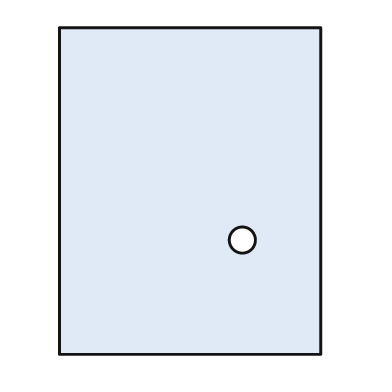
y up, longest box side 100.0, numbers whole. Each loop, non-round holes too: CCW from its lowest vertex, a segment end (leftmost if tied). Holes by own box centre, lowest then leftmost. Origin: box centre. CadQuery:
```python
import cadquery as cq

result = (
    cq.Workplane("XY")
    .moveTo(-40.0, -50.0)
    .lineTo(40.0, -50.0)
    .lineTo(40.0, 50.0)
    .lineTo(-40.0, 50.0)
    .close()
    .moveTo(16.0, -15.0)
    .circle(4.0)
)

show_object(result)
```